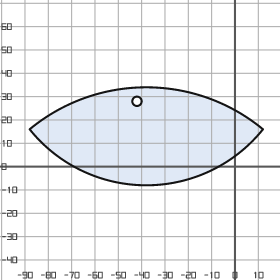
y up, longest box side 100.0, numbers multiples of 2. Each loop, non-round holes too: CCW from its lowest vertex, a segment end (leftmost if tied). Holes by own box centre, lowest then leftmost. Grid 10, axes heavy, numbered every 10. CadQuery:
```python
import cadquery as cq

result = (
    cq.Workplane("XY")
    .moveTo(-88.0, 16.0)
    .threePointArc((-38.0, -8.0), (12.0, 16.0))
    .threePointArc((-38.0, 34.0), (-88.0, 16.0))
    .close()
    .moveTo(-42.0, 28.0)
    .circle(2.0)
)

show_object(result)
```